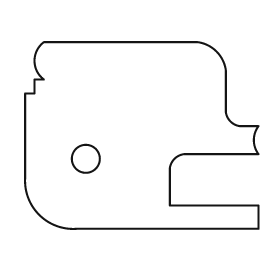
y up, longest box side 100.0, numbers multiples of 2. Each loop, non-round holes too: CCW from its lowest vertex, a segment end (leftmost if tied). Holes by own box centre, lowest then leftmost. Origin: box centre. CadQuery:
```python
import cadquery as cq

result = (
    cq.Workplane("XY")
    .moveTo(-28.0, -40.0)
    .lineTo(50.0, -40.0)
    .lineTo(50.0, -30.0)
    .lineTo(12.0, -30.0)
    .lineTo(12.0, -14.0)
    .threePointArc((14.0, -10.0), (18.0, -8.0))
    .lineTo(50.0, -8.0)
    .threePointArc((48.0, -2.0), (50.0, 4.0))
    .lineTo(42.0, 4.0)
    .threePointArc((38.0, 6.0), (36.0, 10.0))
    .lineTo(36.0, 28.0)
    .threePointArc((32.0, 36.0), (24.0, 40.0))
    .lineTo(-42.0, 40.0)
    .threePointArc((-46.0, 32.0), (-42.0, 24.0))
    .lineTo(-46.0, 24.0)
    .lineTo(-46.0, 18.0)
    .lineTo(-50.0, 18.0)
    .lineTo(-50.0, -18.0)
    .threePointArc((-44.0, -34.0), (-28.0, -40.0))
    .close()
    .moveTo(-24.0, -10.0)
    .circle(6.0)
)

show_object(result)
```